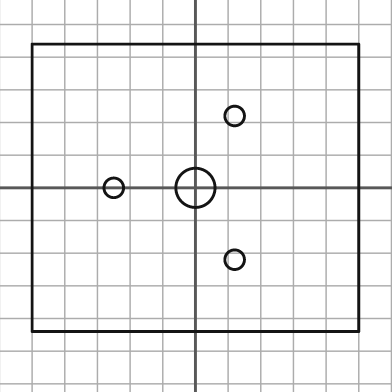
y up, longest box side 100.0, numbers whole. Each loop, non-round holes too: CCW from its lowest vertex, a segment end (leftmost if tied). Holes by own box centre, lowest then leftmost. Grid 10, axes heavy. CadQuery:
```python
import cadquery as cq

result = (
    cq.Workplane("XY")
    .moveTo(-50.0, -44.0)
    .lineTo(50.0, -44.0)
    .lineTo(50.0, 44.0)
    .lineTo(-50.0, 44.0)
    .close()
    .moveTo(12.0, -22.0)
    .circle(3.0)
    .moveTo(-25.0, 0.0)
    .circle(3.0)
    .moveTo(0.0, 0.0)
    .circle(6.0)
    .moveTo(12.0, 22.0)
    .circle(3.0)
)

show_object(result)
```